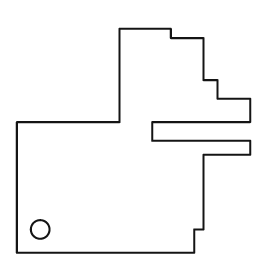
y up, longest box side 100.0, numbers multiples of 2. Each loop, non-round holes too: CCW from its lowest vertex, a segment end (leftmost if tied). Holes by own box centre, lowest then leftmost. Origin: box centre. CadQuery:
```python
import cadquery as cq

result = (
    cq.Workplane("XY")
    .moveTo(-50.0, -48.0)
    .lineTo(26.0, -48.0)
    .lineTo(26.0, -38.0)
    .lineTo(30.0, -38.0)
    .lineTo(30.0, -6.0)
    .lineTo(50.0, -6.0)
    .lineTo(50.0, 0.0)
    .lineTo(8.0, 0.0)
    .lineTo(8.0, 8.0)
    .lineTo(50.0, 8.0)
    .lineTo(50.0, 18.0)
    .lineTo(36.0, 18.0)
    .lineTo(36.0, 26.0)
    .lineTo(30.0, 26.0)
    .lineTo(30.0, 44.0)
    .lineTo(16.0, 44.0)
    .lineTo(16.0, 48.0)
    .lineTo(-6.0, 48.0)
    .lineTo(-6.0, 8.0)
    .lineTo(-50.0, 8.0)
    .close()
    .moveTo(-40.0, -38.0)
    .circle(4.0)
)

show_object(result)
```